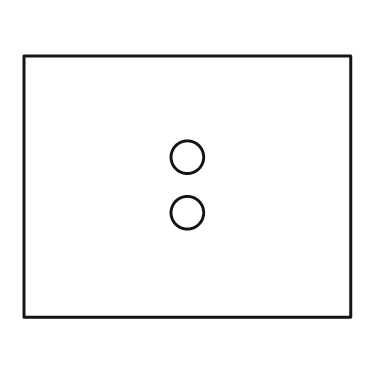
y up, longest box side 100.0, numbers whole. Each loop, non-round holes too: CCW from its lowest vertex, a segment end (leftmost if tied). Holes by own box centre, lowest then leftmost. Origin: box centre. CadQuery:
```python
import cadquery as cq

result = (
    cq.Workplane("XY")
    .moveTo(-50.0, -40.0)
    .lineTo(50.0, -40.0)
    .lineTo(50.0, 40.0)
    .lineTo(-50.0, 40.0)
    .close()
    .moveTo(0.0, -8.0)
    .circle(5.0)
    .moveTo(0.0, 9.0)
    .circle(5.0)
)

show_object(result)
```